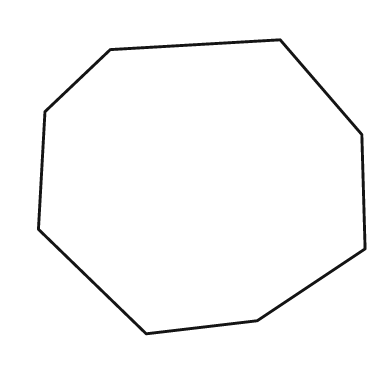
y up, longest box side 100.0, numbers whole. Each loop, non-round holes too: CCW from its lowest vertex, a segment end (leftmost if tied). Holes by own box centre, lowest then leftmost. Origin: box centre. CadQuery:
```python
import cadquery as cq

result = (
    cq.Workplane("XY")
    .moveTo(-17.0, -45.0)
    .lineTo(17.0, -41.0)
    .lineTo(50.0, -19.0)
    .lineTo(49.0, 16.0)
    .lineTo(24.0, 45.0)
    .lineTo(-28.0, 42.0)
    .lineTo(-48.0, 23.0)
    .lineTo(-50.0, -13.0)
    .close()
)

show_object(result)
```